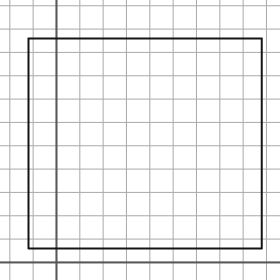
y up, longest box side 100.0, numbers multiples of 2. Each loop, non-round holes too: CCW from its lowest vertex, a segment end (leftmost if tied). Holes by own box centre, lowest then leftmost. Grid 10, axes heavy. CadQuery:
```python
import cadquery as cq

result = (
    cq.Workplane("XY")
    .moveTo(-12.0, 6.0)
    .lineTo(88.0, 6.0)
    .lineTo(88.0, 96.0)
    .lineTo(-12.0, 96.0)
    .close()
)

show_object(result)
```